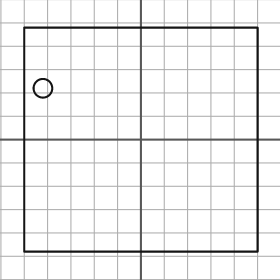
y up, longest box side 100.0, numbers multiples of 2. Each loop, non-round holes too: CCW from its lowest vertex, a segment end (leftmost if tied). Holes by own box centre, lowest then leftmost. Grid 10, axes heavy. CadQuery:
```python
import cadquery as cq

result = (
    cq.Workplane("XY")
    .moveTo(-50.0, -48.0)
    .lineTo(50.0, -48.0)
    .lineTo(50.0, 48.0)
    .lineTo(-50.0, 48.0)
    .close()
    .moveTo(-42.0, 22.0)
    .circle(4.0)
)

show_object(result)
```